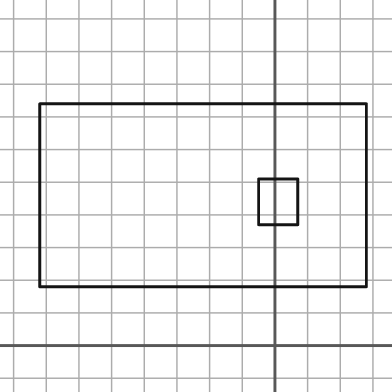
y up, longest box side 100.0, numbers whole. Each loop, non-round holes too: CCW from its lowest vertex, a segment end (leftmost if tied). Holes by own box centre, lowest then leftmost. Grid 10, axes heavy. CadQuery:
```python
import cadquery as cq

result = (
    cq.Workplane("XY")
    .moveTo(-72.0, 18.0)
    .lineTo(28.0, 18.0)
    .lineTo(28.0, 74.0)
    .lineTo(-72.0, 74.0)
    .close()
    .moveTo(-5.0, 37.0)
    .lineTo(7.0, 37.0)
    .lineTo(7.0, 51.0)
    .lineTo(-5.0, 51.0)
    .close()
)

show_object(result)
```